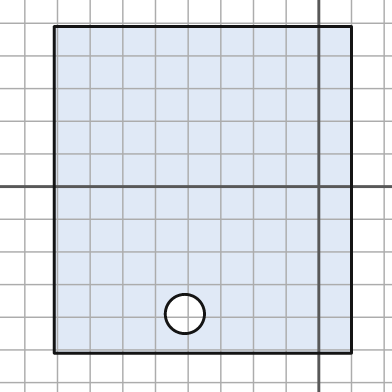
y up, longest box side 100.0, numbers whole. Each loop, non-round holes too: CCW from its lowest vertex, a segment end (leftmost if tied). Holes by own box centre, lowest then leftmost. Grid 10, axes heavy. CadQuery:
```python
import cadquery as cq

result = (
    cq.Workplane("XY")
    .moveTo(-81.0, -51.0)
    .lineTo(10.0, -51.0)
    .lineTo(10.0, 49.0)
    .lineTo(-81.0, 49.0)
    .close()
    .moveTo(-41.0, -39.0)
    .circle(6.0)
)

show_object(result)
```